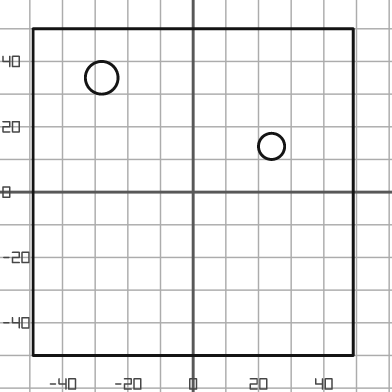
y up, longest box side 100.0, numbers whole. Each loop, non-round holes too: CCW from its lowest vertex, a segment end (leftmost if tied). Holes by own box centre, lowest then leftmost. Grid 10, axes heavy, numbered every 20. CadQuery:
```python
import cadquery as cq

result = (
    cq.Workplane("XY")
    .moveTo(-49.0, -50.0)
    .lineTo(49.0, -50.0)
    .lineTo(49.0, 50.0)
    .lineTo(-49.0, 50.0)
    .close()
    .moveTo(24.0, 14.0)
    .circle(4.0)
    .moveTo(-28.0, 35.0)
    .circle(5.0)
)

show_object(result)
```